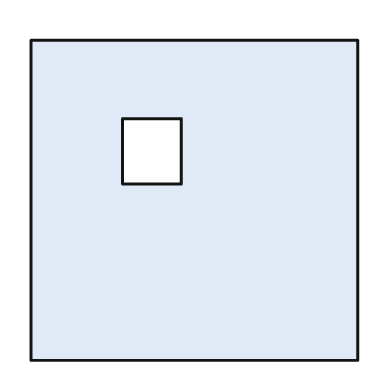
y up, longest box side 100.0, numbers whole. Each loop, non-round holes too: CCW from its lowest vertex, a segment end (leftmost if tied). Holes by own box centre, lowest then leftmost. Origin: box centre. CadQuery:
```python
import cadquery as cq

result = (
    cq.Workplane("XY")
    .moveTo(-50.0, -49.0)
    .lineTo(50.0, -49.0)
    .lineTo(50.0, 49.0)
    .lineTo(-50.0, 49.0)
    .close()
    .moveTo(-22.0, 5.0)
    .lineTo(-4.0, 5.0)
    .lineTo(-4.0, 25.0)
    .lineTo(-22.0, 25.0)
    .close()
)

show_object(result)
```